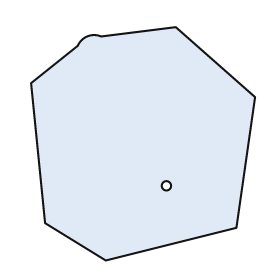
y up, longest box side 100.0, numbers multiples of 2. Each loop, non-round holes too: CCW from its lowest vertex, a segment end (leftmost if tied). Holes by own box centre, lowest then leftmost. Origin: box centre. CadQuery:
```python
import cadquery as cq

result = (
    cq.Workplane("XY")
    .moveTo(-16.0, -50.0)
    .lineTo(40.0, -36.0)
    .lineTo(48.0, 20.0)
    .lineTo(14.0, 50.0)
    .lineTo(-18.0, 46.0)
    .threePointArc((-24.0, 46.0), (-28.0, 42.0))
    .lineTo(-48.0, 26.0)
    .lineTo(-42.0, -34.0)
    .close()
    .moveTo(10.0, -18.0)
    .circle(2.0)
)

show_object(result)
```